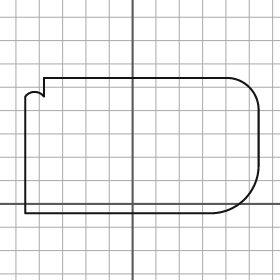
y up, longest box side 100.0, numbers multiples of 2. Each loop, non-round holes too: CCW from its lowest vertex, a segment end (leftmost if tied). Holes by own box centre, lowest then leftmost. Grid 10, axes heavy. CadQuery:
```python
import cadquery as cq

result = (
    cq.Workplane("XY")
    .moveTo(-46.0, -4.0)
    .lineTo(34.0, -4.0)
    .threePointArc((48.0, 2.0), (54.0, 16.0))
    .lineTo(54.0, 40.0)
    .threePointArc((50.0, 50.0), (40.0, 54.0))
    .lineTo(-38.0, 54.0)
    .lineTo(-38.0, 46.0)
    .threePointArc((-42.0, 48.0), (-46.0, 46.0))
    .close()
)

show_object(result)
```